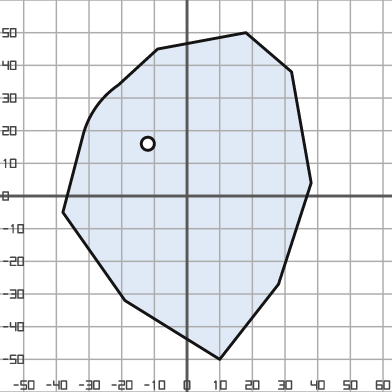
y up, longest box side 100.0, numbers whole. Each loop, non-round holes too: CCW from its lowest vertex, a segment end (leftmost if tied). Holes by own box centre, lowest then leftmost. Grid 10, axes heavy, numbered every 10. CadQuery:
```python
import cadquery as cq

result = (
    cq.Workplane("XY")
    .moveTo(10.0, -50.0)
    .lineTo(28.0, -27.0)
    .lineTo(38.0, 4.0)
    .lineTo(32.0, 38.0)
    .lineTo(18.0, 50.0)
    .lineTo(-9.0, 45.0)
    .lineTo(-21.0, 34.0)
    .threePointArc((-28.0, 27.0), (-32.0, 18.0))
    .lineTo(-38.0, -5.0)
    .lineTo(-19.0, -32.0)
    .close()
    .moveTo(-12.0, 16.0)
    .circle(2.0)
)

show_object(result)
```